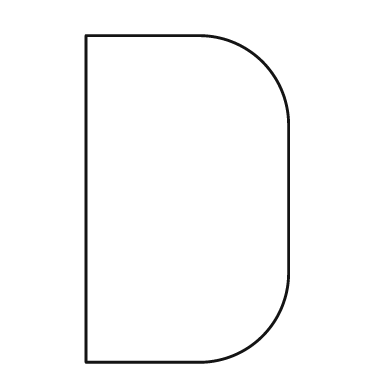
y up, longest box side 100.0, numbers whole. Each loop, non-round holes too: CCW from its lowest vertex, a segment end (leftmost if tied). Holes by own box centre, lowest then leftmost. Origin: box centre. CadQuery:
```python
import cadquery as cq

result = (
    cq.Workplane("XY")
    .moveTo(-31.0, -50.0)
    .lineTo(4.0, -50.0)
    .threePointArc((23.0, -42.0), (31.0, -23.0))
    .lineTo(31.0, 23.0)
    .threePointArc((23.0, 42.0), (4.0, 50.0))
    .lineTo(-31.0, 50.0)
    .close()
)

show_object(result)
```